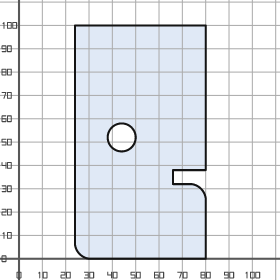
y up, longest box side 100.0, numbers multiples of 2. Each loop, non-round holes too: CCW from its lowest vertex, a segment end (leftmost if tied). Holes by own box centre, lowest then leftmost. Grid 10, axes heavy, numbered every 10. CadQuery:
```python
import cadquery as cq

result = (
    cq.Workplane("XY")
    .moveTo(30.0, 0.0)
    .lineTo(80.0, 0.0)
    .lineTo(80.0, 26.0)
    .threePointArc((78.0, 30.0), (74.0, 32.0))
    .lineTo(66.0, 32.0)
    .lineTo(66.0, 38.0)
    .lineTo(80.0, 38.0)
    .lineTo(80.0, 100.0)
    .lineTo(24.0, 100.0)
    .lineTo(24.0, 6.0)
    .threePointArc((26.0, 2.0), (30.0, 0.0))
    .close()
    .moveTo(44.0, 52.0)
    .circle(6.0)
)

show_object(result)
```